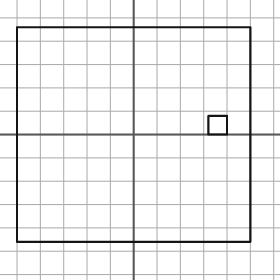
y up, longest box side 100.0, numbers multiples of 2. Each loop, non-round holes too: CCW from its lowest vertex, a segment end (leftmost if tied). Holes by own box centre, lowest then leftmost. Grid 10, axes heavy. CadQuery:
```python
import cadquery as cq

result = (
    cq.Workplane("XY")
    .moveTo(-50.0, -46.0)
    .lineTo(50.0, -46.0)
    .lineTo(50.0, 46.0)
    .lineTo(-50.0, 46.0)
    .close()
    .moveTo(32.0, 0.0)
    .lineTo(40.0, 0.0)
    .lineTo(40.0, 8.0)
    .lineTo(32.0, 8.0)
    .close()
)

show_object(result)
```